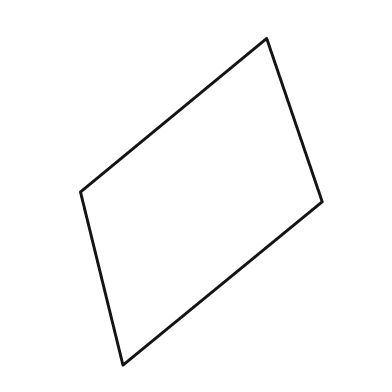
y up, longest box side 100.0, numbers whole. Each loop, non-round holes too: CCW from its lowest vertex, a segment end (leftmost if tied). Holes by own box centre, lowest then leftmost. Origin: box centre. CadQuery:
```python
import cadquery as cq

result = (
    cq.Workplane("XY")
    .moveTo(-24.0, -50.0)
    .lineTo(37.0, 0.0)
    .lineTo(20.0, 50.0)
    .lineTo(-37.0, 3.0)
    .close()
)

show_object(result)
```